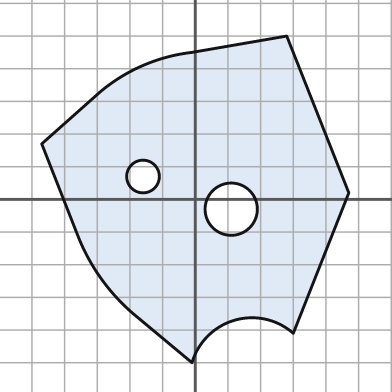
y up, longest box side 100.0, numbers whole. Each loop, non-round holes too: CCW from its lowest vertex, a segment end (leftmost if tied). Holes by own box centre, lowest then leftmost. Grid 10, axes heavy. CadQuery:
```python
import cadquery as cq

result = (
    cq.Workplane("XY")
    .moveTo(-1.0, -50.0)
    .threePointArc((12.0, -37.0), (30.0, -41.0))
    .lineTo(47.0, 2.0)
    .lineTo(28.0, 50.0)
    .lineTo(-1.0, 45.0)
    .threePointArc((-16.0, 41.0), (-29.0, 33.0))
    .lineTo(-47.0, 17.0)
    .lineTo(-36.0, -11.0)
    .threePointArc((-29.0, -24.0), (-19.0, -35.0))
    .close()
    .moveTo(11.0, -3.0)
    .circle(8.0)
    .moveTo(-16.0, 7.0)
    .circle(5.0)
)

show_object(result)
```